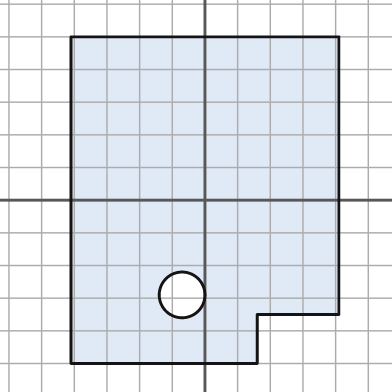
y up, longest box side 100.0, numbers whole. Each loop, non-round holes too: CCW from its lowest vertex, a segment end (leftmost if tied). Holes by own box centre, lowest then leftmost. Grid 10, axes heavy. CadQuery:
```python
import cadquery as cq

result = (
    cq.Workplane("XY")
    .moveTo(-41.0, -50.0)
    .lineTo(16.0, -50.0)
    .lineTo(16.0, -35.0)
    .lineTo(41.0, -35.0)
    .lineTo(41.0, 50.0)
    .lineTo(-41.0, 50.0)
    .close()
    .moveTo(-7.0, -29.0)
    .circle(7.0)
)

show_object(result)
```